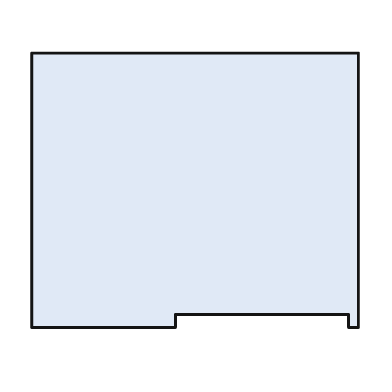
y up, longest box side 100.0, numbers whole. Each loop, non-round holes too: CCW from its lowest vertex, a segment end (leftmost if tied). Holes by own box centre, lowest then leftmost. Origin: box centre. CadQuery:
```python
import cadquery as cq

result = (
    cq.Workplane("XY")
    .moveTo(-50.0, -42.0)
    .lineTo(-6.0, -42.0)
    .lineTo(-6.0, -38.0)
    .lineTo(47.0, -38.0)
    .lineTo(47.0, -42.0)
    .lineTo(50.0, -42.0)
    .lineTo(50.0, 42.0)
    .lineTo(-50.0, 42.0)
    .close()
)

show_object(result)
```